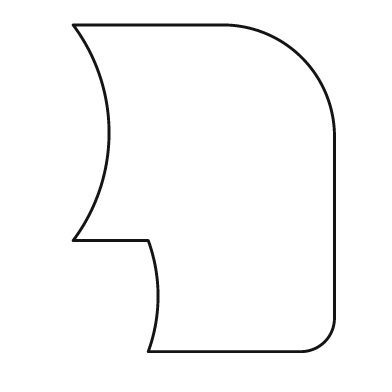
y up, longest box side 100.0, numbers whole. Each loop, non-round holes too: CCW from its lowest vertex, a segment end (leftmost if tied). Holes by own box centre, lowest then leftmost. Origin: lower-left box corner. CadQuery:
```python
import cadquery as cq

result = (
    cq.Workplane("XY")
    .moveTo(23.0, 0.0)
    .lineTo(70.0, 0.0)
    .threePointArc((77.0, 3.0), (80.0, 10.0))
    .lineTo(80.0, 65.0)
    .threePointArc((70.0, 90.0), (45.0, 100.0))
    .lineTo(0.0, 100.0)
    .threePointArc((11.0, 67.0), (0.0, 34.0))
    .lineTo(23.0, 34.0)
    .threePointArc((26.0, 17.0), (23.0, 0.0))
    .close()
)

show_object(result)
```